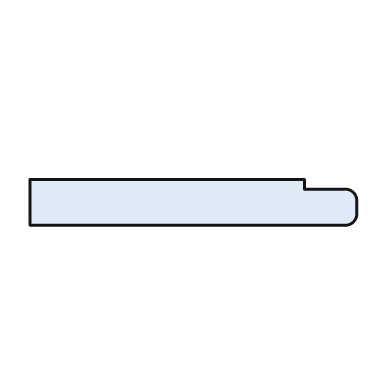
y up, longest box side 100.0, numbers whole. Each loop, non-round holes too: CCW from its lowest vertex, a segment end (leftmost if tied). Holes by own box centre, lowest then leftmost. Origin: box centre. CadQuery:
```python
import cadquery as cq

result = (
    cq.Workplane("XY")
    .moveTo(-50.0, -7.0)
    .lineTo(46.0, -7.0)
    .threePointArc((49.0, -6.0), (50.0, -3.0))
    .lineTo(50.0, 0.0)
    .threePointArc((49.0, 3.0), (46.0, 4.0))
    .lineTo(34.0, 4.0)
    .lineTo(34.0, 7.0)
    .lineTo(-50.0, 7.0)
    .close()
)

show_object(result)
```